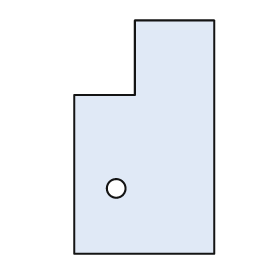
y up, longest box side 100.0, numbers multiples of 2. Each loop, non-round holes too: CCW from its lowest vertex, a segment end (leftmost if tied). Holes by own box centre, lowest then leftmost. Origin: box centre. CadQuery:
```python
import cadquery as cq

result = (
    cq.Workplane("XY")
    .moveTo(-30.0, -50.0)
    .lineTo(30.0, -50.0)
    .lineTo(30.0, 50.0)
    .lineTo(-4.0, 50.0)
    .lineTo(-4.0, 18.0)
    .lineTo(-30.0, 18.0)
    .close()
    .moveTo(-12.0, -22.0)
    .circle(4.0)
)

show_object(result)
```